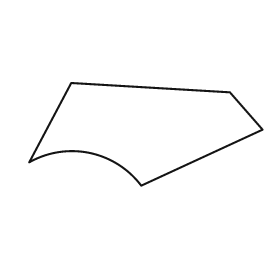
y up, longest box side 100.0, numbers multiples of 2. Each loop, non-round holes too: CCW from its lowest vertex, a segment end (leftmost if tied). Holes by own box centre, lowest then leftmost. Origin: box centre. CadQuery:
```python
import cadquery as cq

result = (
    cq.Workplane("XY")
    .moveTo(-2.0, -22.0)
    .lineTo(50.0, 2.0)
    .lineTo(36.0, 18.0)
    .lineTo(-32.0, 22.0)
    .lineTo(-50.0, -12.0)
    .threePointArc((-24.0, -8.0), (-2.0, -22.0))
    .close()
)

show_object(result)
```